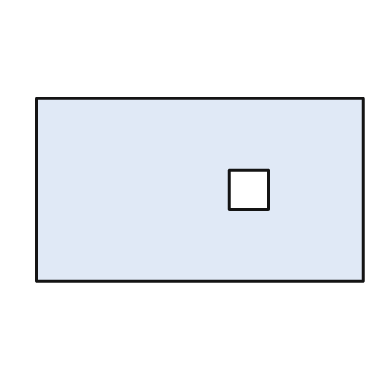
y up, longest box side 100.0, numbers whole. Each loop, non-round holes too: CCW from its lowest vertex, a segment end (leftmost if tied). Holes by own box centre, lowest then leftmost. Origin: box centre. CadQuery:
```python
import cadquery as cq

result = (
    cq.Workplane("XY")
    .moveTo(-50.0, -28.0)
    .lineTo(50.0, -28.0)
    .lineTo(50.0, 28.0)
    .lineTo(-50.0, 28.0)
    .close()
    .moveTo(9.0, -6.0)
    .lineTo(21.0, -6.0)
    .lineTo(21.0, 6.0)
    .lineTo(9.0, 6.0)
    .close()
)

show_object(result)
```